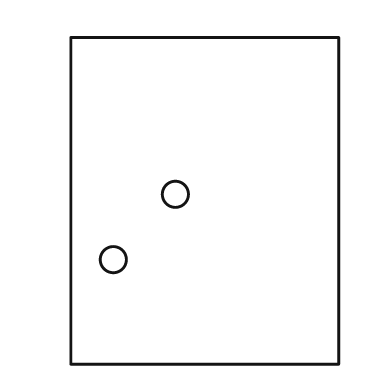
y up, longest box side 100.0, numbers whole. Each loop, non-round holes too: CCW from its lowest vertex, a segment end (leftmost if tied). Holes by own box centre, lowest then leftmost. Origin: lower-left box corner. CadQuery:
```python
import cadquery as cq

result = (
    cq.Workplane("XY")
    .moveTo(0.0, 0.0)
    .lineTo(82.0, 0.0)
    .lineTo(82.0, 100.0)
    .lineTo(0.0, 100.0)
    .close()
    .moveTo(13.0, 32.0)
    .circle(4.0)
    .moveTo(32.0, 52.0)
    .circle(4.0)
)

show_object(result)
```